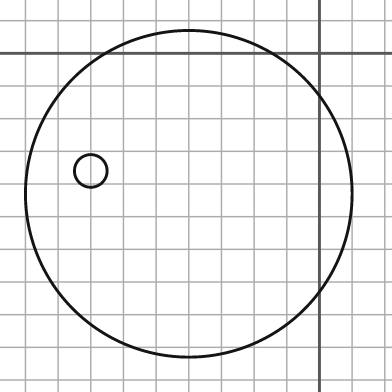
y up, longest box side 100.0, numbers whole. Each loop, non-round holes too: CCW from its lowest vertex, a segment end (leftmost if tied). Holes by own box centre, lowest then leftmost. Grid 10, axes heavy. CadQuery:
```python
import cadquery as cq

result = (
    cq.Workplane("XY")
    .moveTo(-40.0, -43.0)
    .circle(50.0)
    .moveTo(-70.0, -36.0)
    .circle(5.0)
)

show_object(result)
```